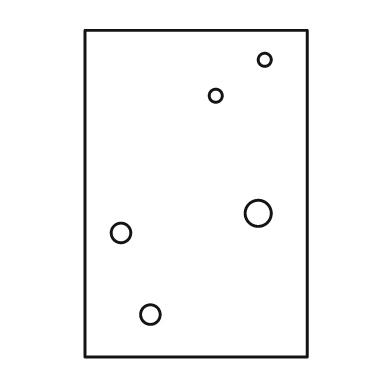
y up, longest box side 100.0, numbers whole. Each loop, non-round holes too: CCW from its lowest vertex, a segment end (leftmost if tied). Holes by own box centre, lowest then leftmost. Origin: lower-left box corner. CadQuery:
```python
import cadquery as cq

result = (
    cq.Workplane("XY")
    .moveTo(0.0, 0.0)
    .lineTo(68.0, 0.0)
    .lineTo(68.0, 100.0)
    .lineTo(0.0, 100.0)
    .close()
    .moveTo(20.0, 13.0)
    .circle(3.0)
    .moveTo(11.0, 38.0)
    .circle(3.0)
    .moveTo(53.0, 44.0)
    .circle(4.0)
    .moveTo(40.0, 80.0)
    .circle(2.0)
    .moveTo(55.0, 91.0)
    .circle(2.0)
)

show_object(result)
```